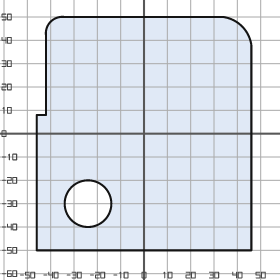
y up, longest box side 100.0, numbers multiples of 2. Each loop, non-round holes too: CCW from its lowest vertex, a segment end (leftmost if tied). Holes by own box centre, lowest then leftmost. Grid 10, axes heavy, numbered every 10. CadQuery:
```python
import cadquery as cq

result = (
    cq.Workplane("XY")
    .moveTo(-46.0, -50.0)
    .lineTo(46.0, -50.0)
    .lineTo(46.0, 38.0)
    .threePointArc((42.0, 46.0), (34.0, 50.0))
    .lineTo(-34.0, 50.0)
    .threePointArc((-40.0, 48.0), (-42.0, 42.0))
    .lineTo(-42.0, 8.0)
    .lineTo(-46.0, 8.0)
    .close()
    .moveTo(-24.0, -30.0)
    .circle(10.0)
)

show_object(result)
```